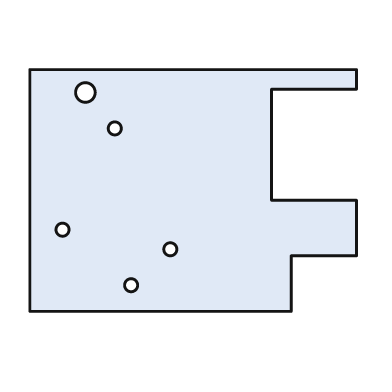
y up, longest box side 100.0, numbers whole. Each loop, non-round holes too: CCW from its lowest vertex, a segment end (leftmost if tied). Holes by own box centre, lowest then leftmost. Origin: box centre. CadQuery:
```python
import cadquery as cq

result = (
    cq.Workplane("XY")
    .moveTo(-50.0, -37.0)
    .lineTo(30.0, -37.0)
    .lineTo(30.0, -20.0)
    .lineTo(50.0, -20.0)
    .lineTo(50.0, -3.0)
    .lineTo(24.0, -3.0)
    .lineTo(24.0, 31.0)
    .lineTo(50.0, 31.0)
    .lineTo(50.0, 37.0)
    .lineTo(-50.0, 37.0)
    .close()
    .moveTo(-19.0, -29.0)
    .circle(2.0)
    .moveTo(-7.0, -18.0)
    .circle(2.0)
    .moveTo(-40.0, -12.0)
    .circle(2.0)
    .moveTo(-24.0, 19.0)
    .circle(2.0)
    .moveTo(-33.0, 30.0)
    .circle(3.0)
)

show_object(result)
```